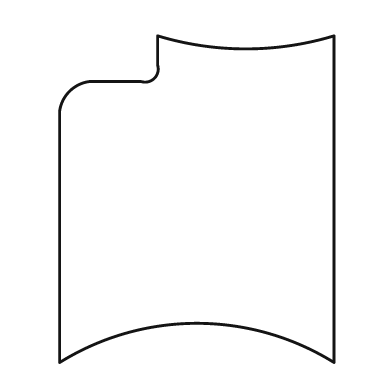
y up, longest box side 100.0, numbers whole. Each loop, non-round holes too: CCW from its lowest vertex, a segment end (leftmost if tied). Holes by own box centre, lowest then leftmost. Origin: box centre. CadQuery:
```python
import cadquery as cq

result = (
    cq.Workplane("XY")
    .moveTo(-42.0, -50.0)
    .threePointArc((0.0, -38.0), (42.0, -50.0))
    .lineTo(42.0, 50.0)
    .threePointArc((15.0, 46.0), (-12.0, 50.0))
    .lineTo(-12.0, 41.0)
    .threePointArc((-13.0, 37.0), (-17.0, 36.0))
    .lineTo(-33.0, 36.0)
    .threePointArc((-39.0, 33.0), (-42.0, 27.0))
    .close()
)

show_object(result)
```